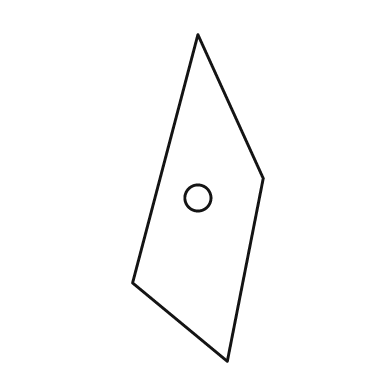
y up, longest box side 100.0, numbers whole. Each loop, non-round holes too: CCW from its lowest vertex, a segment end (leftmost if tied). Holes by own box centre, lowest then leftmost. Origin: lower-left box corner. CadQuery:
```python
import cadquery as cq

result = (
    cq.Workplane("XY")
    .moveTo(29.0, 0.0)
    .lineTo(40.0, 56.0)
    .lineTo(20.0, 100.0)
    .lineTo(0.0, 24.0)
    .close()
    .moveTo(20.0, 50.0)
    .circle(4.0)
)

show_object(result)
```